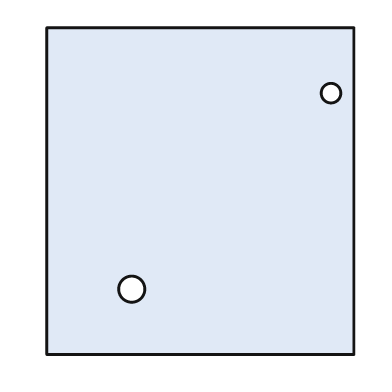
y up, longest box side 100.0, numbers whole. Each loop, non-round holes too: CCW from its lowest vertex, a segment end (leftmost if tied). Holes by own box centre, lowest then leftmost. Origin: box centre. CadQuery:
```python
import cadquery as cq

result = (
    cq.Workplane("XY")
    .moveTo(-47.0, -50.0)
    .lineTo(47.0, -50.0)
    .lineTo(47.0, 50.0)
    .lineTo(-47.0, 50.0)
    .close()
    .moveTo(-21.0, -30.0)
    .circle(4.0)
    .moveTo(40.0, 30.0)
    .circle(3.0)
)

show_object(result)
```